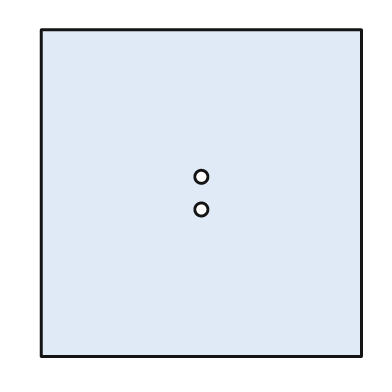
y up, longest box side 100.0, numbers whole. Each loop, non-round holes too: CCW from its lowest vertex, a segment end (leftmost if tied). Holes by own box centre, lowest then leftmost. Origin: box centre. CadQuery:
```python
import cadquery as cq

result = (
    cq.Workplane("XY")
    .moveTo(-49.0, -50.0)
    .lineTo(49.0, -50.0)
    .lineTo(49.0, 50.0)
    .lineTo(-49.0, 50.0)
    .close()
    .moveTo(0.0, -5.0)
    .circle(2.0)
    .moveTo(0.0, 5.0)
    .circle(2.0)
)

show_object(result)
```